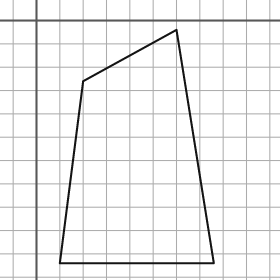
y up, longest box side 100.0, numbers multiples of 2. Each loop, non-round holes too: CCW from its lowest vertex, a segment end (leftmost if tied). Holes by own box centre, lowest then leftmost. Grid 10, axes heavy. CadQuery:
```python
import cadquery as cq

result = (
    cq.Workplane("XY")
    .moveTo(10.0, -104.0)
    .lineTo(76.0, -104.0)
    .lineTo(60.0, -4.0)
    .lineTo(20.0, -26.0)
    .close()
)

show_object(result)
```